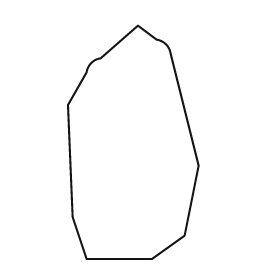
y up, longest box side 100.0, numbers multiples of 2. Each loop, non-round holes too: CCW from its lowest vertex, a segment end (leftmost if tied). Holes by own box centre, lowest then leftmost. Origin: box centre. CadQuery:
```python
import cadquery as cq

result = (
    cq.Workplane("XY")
    .moveTo(-20.0, -50.0)
    .lineTo(8.0, -50.0)
    .lineTo(22.0, -40.0)
    .lineTo(28.0, -10.0)
    .lineTo(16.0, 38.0)
    .threePointArc((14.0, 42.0), (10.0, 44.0))
    .lineTo(2.0, 50.0)
    .lineTo(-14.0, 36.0)
    .threePointArc((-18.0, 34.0), (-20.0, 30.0))
    .lineTo(-28.0, 16.0)
    .lineTo(-26.0, -32.0)
    .close()
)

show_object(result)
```